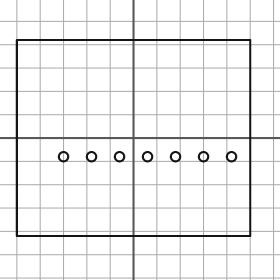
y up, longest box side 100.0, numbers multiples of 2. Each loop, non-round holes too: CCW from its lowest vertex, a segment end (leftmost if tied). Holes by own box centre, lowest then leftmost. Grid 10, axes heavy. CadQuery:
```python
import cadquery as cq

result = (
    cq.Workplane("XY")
    .moveTo(-50.0, -42.0)
    .lineTo(50.0, -42.0)
    .lineTo(50.0, 42.0)
    .lineTo(-50.0, 42.0)
    .close()
    .moveTo(-30.0, -8.0)
    .circle(2.0)
    .moveTo(-18.0, -8.0)
    .circle(2.0)
    .moveTo(-6.0, -8.0)
    .circle(2.0)
    .moveTo(6.0, -8.0)
    .circle(2.0)
    .moveTo(18.0, -8.0)
    .circle(2.0)
    .moveTo(30.0, -8.0)
    .circle(2.0)
    .moveTo(42.0, -8.0)
    .circle(2.0)
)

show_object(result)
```